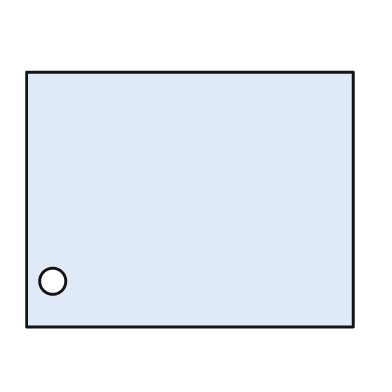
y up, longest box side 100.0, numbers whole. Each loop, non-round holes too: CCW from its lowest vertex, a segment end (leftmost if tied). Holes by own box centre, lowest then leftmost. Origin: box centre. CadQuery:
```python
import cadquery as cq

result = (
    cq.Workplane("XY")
    .moveTo(-50.0, -39.0)
    .lineTo(50.0, -39.0)
    .lineTo(50.0, 39.0)
    .lineTo(-50.0, 39.0)
    .close()
    .moveTo(-42.0, -25.0)
    .circle(4.0)
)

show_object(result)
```